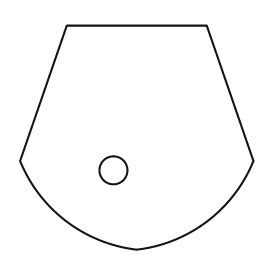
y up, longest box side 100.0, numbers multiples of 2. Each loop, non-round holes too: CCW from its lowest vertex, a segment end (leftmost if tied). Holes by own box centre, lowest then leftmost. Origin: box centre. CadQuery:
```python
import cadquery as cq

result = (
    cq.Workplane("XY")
    .moveTo(0.0, -48.0)
    .threePointArc((30.0, -36.0), (50.0, -10.0))
    .lineTo(30.0, 48.0)
    .lineTo(-30.0, 48.0)
    .lineTo(-50.0, -10.0)
    .threePointArc((-30.0, -36.0), (0.0, -48.0))
    .close()
    .moveTo(-10.0, -14.0)
    .circle(6.0)
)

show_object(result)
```